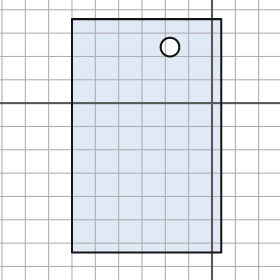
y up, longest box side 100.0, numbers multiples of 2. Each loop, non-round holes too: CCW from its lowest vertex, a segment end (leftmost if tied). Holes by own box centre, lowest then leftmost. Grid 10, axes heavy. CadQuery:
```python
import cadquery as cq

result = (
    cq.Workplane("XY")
    .moveTo(-60.0, -64.0)
    .lineTo(4.0, -64.0)
    .lineTo(4.0, 36.0)
    .lineTo(-60.0, 36.0)
    .close()
    .moveTo(-18.0, 24.0)
    .circle(4.0)
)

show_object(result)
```